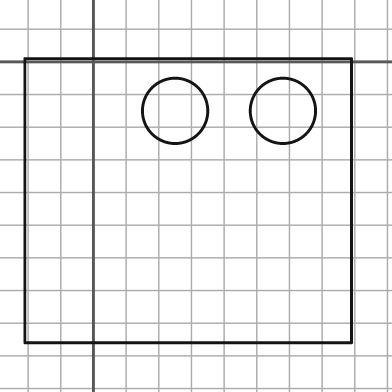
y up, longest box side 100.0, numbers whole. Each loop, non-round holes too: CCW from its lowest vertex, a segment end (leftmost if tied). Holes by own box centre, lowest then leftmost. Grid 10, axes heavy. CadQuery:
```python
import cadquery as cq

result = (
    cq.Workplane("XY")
    .moveTo(-21.0, -86.0)
    .lineTo(79.0, -86.0)
    .lineTo(79.0, 1.0)
    .lineTo(-21.0, 1.0)
    .close()
    .moveTo(25.0, -15.0)
    .circle(10.0)
    .moveTo(58.0, -15.0)
    .circle(10.0)
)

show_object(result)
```